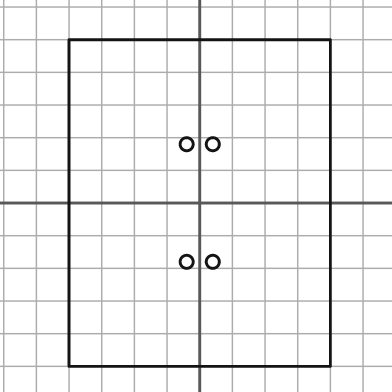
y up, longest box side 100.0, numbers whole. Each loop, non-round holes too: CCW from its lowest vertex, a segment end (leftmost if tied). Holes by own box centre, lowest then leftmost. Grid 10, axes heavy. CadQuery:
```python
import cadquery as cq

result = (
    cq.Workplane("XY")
    .moveTo(-40.0, -50.0)
    .lineTo(40.0, -50.0)
    .lineTo(40.0, 50.0)
    .lineTo(-40.0, 50.0)
    .close()
    .moveTo(-4.0, -18.0)
    .circle(2.0)
    .moveTo(4.0, -18.0)
    .circle(2.0)
    .moveTo(-4.0, 18.0)
    .circle(2.0)
    .moveTo(4.0, 18.0)
    .circle(2.0)
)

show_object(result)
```